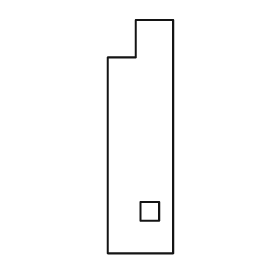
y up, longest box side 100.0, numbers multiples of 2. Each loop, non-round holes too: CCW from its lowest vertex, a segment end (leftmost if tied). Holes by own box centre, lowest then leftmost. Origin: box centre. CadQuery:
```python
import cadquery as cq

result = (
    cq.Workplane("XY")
    .moveTo(-14.0, -50.0)
    .lineTo(14.0, -50.0)
    .lineTo(14.0, 50.0)
    .lineTo(-2.0, 50.0)
    .lineTo(-2.0, 34.0)
    .lineTo(-14.0, 34.0)
    .close()
    .moveTo(0.0, -36.0)
    .lineTo(8.0, -36.0)
    .lineTo(8.0, -28.0)
    .lineTo(0.0, -28.0)
    .close()
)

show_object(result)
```